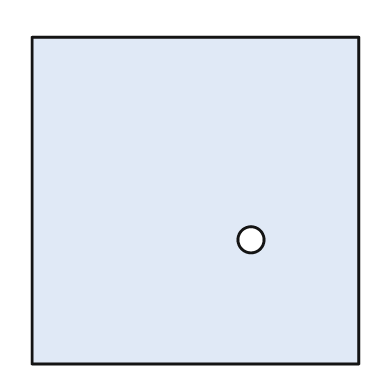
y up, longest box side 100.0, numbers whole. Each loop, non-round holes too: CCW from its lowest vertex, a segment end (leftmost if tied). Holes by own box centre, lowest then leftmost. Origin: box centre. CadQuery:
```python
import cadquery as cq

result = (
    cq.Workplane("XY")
    .moveTo(-50.0, -50.0)
    .lineTo(50.0, -50.0)
    .lineTo(50.0, 50.0)
    .lineTo(-50.0, 50.0)
    .close()
    .moveTo(17.0, -12.0)
    .circle(4.0)
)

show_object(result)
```